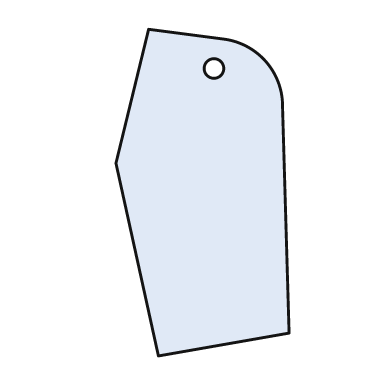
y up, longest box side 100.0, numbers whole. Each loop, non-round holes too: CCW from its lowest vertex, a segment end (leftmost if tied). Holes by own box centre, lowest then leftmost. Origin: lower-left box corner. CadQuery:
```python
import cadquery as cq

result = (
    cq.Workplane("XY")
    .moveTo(13.0, 0.0)
    .lineTo(53.0, 7.0)
    .lineTo(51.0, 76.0)
    .threePointArc((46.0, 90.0), (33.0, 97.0))
    .lineTo(10.0, 100.0)
    .lineTo(0.0, 59.0)
    .close()
    .moveTo(30.0, 88.0)
    .circle(3.0)
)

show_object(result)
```